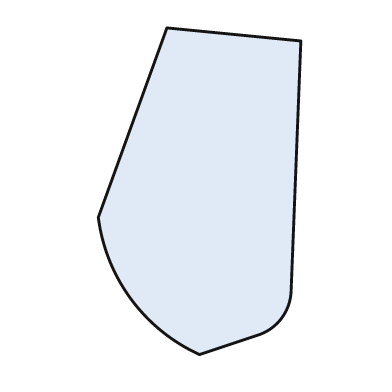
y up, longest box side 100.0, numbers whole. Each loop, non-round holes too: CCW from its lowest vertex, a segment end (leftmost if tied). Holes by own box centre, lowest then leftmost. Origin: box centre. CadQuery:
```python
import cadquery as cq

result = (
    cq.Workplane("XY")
    .moveTo(0.0, -50.0)
    .lineTo(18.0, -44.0)
    .threePointArc((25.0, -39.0), (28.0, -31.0))
    .lineTo(31.0, 46.0)
    .lineTo(-10.0, 50.0)
    .lineTo(-31.0, -8.0)
    .threePointArc((-21.0, -33.0), (0.0, -50.0))
    .close()
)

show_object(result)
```